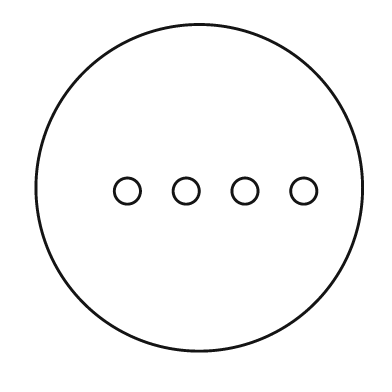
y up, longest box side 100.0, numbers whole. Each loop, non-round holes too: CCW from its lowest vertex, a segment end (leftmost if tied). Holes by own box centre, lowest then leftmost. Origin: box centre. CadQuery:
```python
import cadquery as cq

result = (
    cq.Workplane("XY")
    .moveTo(0.0, 0.0)
    .circle(50.0)
    .moveTo(-22.0, -1.0)
    .circle(4.0)
    .moveTo(-4.0, -1.0)
    .circle(4.0)
    .moveTo(14.0, -1.0)
    .circle(4.0)
    .moveTo(32.0, -1.0)
    .circle(4.0)
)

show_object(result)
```